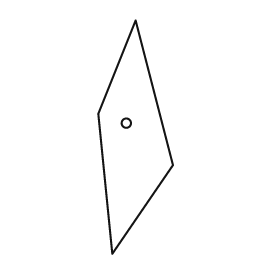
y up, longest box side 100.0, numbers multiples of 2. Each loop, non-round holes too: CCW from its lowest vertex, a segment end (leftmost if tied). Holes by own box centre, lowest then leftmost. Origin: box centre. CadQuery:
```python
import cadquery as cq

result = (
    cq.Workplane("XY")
    .moveTo(-10.0, -50.0)
    .lineTo(16.0, -12.0)
    .lineTo(0.0, 50.0)
    .lineTo(-16.0, 10.0)
    .close()
    .moveTo(-4.0, 6.0)
    .circle(2.0)
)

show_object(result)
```